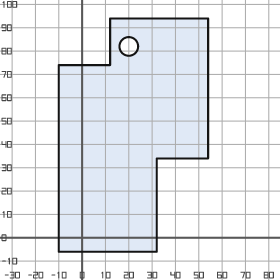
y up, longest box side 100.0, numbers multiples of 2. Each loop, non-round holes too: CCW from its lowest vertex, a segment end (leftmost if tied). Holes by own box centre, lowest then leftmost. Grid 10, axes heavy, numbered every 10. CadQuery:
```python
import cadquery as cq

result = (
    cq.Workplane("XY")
    .moveTo(-10.0, -6.0)
    .lineTo(32.0, -6.0)
    .lineTo(32.0, 34.0)
    .lineTo(54.0, 34.0)
    .lineTo(54.0, 94.0)
    .lineTo(12.0, 94.0)
    .lineTo(12.0, 74.0)
    .lineTo(-10.0, 74.0)
    .close()
    .moveTo(20.0, 82.0)
    .circle(4.0)
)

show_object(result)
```